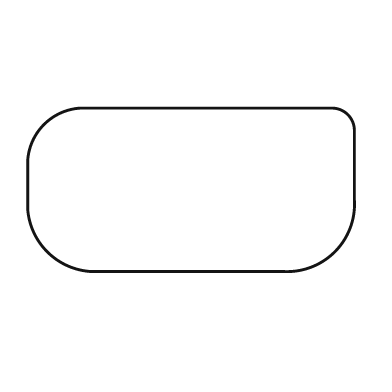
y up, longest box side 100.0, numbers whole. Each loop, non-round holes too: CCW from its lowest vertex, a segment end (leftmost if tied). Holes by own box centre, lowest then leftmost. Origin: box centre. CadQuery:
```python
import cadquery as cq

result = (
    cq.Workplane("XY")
    .moveTo(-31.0, -25.0)
    .lineTo(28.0, -25.0)
    .threePointArc((44.0, -19.0), (50.0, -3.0))
    .lineTo(50.0, 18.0)
    .threePointArc((48.0, 23.0), (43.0, 25.0))
    .lineTo(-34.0, 25.0)
    .threePointArc((-45.0, 20.0), (-50.0, 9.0))
    .lineTo(-50.0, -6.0)
    .threePointArc((-44.0, -19.0), (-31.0, -25.0))
    .close()
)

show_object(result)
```